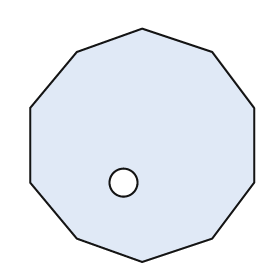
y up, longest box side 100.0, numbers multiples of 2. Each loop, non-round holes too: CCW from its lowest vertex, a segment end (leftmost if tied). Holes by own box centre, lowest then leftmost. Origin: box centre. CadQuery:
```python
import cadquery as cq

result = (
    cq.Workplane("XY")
    .moveTo(0.0, -50.0)
    .lineTo(30.0, -40.0)
    .lineTo(48.0, -16.0)
    .lineTo(48.0, 16.0)
    .lineTo(30.0, 40.0)
    .lineTo(0.0, 50.0)
    .lineTo(-28.0, 40.0)
    .lineTo(-48.0, 16.0)
    .lineTo(-48.0, -16.0)
    .lineTo(-28.0, -40.0)
    .close()
    .moveTo(-8.0, -16.0)
    .circle(6.0)
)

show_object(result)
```